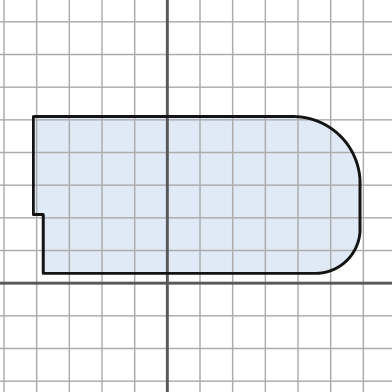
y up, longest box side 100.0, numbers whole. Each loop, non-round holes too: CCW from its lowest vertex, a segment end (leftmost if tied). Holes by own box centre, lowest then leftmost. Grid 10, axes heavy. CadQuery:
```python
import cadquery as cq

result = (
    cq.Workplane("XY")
    .moveTo(-38.0, 3.0)
    .lineTo(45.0, 3.0)
    .threePointArc((55.0, 7.0), (59.0, 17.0))
    .lineTo(59.0, 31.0)
    .threePointArc((53.0, 45.0), (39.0, 51.0))
    .lineTo(-41.0, 51.0)
    .lineTo(-41.0, 21.0)
    .lineTo(-38.0, 21.0)
    .close()
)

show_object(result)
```